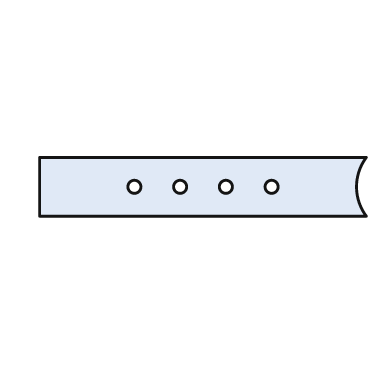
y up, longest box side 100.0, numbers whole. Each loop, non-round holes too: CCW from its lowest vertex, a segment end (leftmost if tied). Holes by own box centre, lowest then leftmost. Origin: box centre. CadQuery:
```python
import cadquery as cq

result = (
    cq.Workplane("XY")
    .moveTo(-50.0, -9.0)
    .lineTo(50.0, -9.0)
    .threePointArc((47.0, 0.0), (50.0, 9.0))
    .lineTo(-50.0, 9.0)
    .close()
    .moveTo(-21.0, 0.0)
    .circle(2.0)
    .moveTo(-7.0, 0.0)
    .circle(2.0)
    .moveTo(7.0, 0.0)
    .circle(2.0)
    .moveTo(21.0, 0.0)
    .circle(2.0)
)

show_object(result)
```